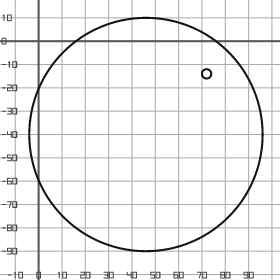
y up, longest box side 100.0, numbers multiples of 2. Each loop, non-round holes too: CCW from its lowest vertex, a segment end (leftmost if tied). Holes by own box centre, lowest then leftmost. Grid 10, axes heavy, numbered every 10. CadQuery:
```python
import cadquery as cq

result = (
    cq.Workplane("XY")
    .moveTo(46.0, -40.0)
    .circle(50.0)
    .moveTo(72.0, -14.0)
    .circle(2.0)
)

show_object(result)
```